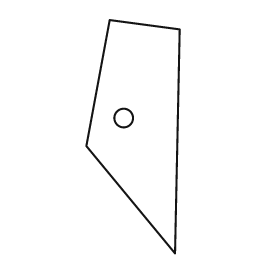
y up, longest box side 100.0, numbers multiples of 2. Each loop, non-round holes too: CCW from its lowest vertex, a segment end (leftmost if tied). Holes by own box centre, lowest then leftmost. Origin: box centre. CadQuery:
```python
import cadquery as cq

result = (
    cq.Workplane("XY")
    .moveTo(18.0, -50.0)
    .lineTo(20.0, 46.0)
    .lineTo(-10.0, 50.0)
    .lineTo(-20.0, -4.0)
    .close()
    .moveTo(-4.0, 8.0)
    .circle(4.0)
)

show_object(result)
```